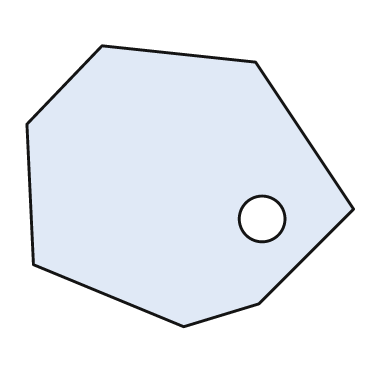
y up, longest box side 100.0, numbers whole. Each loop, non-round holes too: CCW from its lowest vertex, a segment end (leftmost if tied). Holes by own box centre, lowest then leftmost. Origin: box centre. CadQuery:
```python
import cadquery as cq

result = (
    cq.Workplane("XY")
    .moveTo(-2.0, -43.0)
    .lineTo(21.0, -36.0)
    .lineTo(50.0, -7.0)
    .lineTo(20.0, 38.0)
    .lineTo(-27.0, 43.0)
    .lineTo(-50.0, 19.0)
    .lineTo(-48.0, -24.0)
    .close()
    .moveTo(22.0, -10.0)
    .circle(7.0)
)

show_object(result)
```